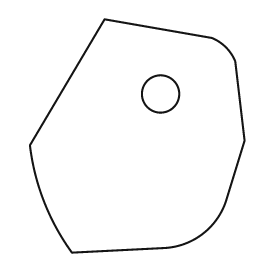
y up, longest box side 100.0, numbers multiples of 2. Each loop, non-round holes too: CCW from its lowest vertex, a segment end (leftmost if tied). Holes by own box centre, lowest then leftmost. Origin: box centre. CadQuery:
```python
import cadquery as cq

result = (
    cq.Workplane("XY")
    .moveTo(-28.0, -50.0)
    .lineTo(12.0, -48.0)
    .threePointArc((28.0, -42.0), (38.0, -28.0))
    .lineTo(46.0, -2.0)
    .lineTo(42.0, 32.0)
    .threePointArc((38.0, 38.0), (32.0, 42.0))
    .lineTo(-14.0, 50.0)
    .lineTo(-46.0, -4.0)
    .threePointArc((-40.0, -28.0), (-28.0, -50.0))
    .close()
    .moveTo(10.0, 18.0)
    .circle(8.0)
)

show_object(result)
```